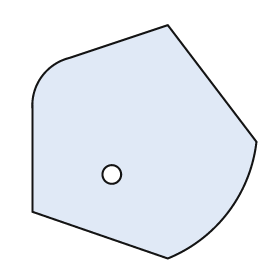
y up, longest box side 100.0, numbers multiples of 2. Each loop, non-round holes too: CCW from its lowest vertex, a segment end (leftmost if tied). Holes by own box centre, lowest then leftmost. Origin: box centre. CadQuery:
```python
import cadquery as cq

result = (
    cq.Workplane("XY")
    .moveTo(10.0, -50.0)
    .threePointArc((36.0, -30.0), (48.0, 0.0))
    .lineTo(10.0, 50.0)
    .lineTo(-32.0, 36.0)
    .threePointArc((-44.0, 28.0), (-48.0, 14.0))
    .lineTo(-48.0, -30.0)
    .close()
    .moveTo(-14.0, -14.0)
    .circle(4.0)
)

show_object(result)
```